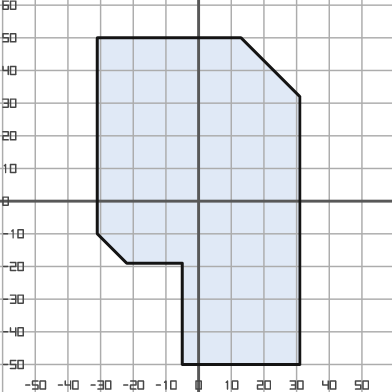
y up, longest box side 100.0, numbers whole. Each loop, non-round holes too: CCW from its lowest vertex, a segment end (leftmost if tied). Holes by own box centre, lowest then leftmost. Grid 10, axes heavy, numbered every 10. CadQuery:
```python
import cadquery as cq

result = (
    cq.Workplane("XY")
    .moveTo(-5.0, -50.0)
    .lineTo(31.0, -50.0)
    .lineTo(31.0, 32.0)
    .lineTo(13.0, 50.0)
    .lineTo(-31.0, 50.0)
    .lineTo(-31.0, -10.0)
    .lineTo(-22.0, -19.0)
    .lineTo(-5.0, -19.0)
    .close()
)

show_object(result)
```